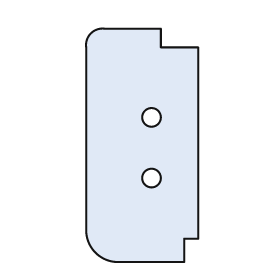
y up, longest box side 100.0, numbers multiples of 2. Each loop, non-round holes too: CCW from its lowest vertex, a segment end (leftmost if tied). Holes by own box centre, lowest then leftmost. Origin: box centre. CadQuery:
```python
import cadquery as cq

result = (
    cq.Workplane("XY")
    .moveTo(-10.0, -50.0)
    .lineTo(18.0, -50.0)
    .lineTo(18.0, -40.0)
    .lineTo(24.0, -40.0)
    .lineTo(24.0, 42.0)
    .lineTo(8.0, 42.0)
    .lineTo(8.0, 50.0)
    .lineTo(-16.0, 50.0)
    .threePointArc((-22.0, 48.0), (-24.0, 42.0))
    .lineTo(-24.0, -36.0)
    .threePointArc((-20.0, -46.0), (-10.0, -50.0))
    .close()
    .moveTo(4.0, -14.0)
    .circle(4.0)
    .moveTo(4.0, 12.0)
    .circle(4.0)
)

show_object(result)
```